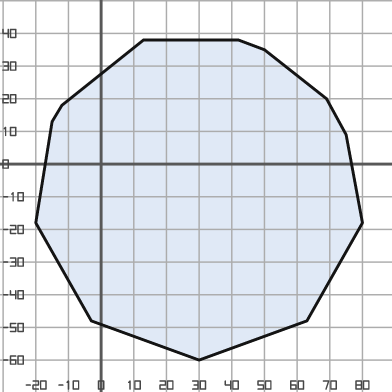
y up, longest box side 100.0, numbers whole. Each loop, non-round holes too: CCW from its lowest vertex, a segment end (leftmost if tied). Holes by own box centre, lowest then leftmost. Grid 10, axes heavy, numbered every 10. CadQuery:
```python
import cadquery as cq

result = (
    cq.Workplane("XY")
    .moveTo(30.0, -60.0)
    .lineTo(63.0, -48.0)
    .lineTo(80.0, -18.0)
    .lineTo(75.0, 9.0)
    .lineTo(69.0, 20.0)
    .lineTo(50.0, 35.0)
    .lineTo(42.0, 38.0)
    .lineTo(13.0, 38.0)
    .lineTo(-12.0, 18.0)
    .lineTo(-15.0, 13.0)
    .lineTo(-20.0, -18.0)
    .lineTo(-3.0, -48.0)
    .close()
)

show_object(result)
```